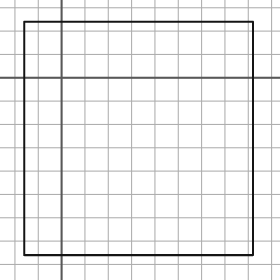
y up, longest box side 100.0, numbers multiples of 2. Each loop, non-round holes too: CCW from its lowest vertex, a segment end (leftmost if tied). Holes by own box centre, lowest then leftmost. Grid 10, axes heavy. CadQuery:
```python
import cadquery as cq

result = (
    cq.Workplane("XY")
    .moveTo(-16.0, -76.0)
    .lineTo(82.0, -76.0)
    .lineTo(82.0, 24.0)
    .lineTo(-16.0, 24.0)
    .close()
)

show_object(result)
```